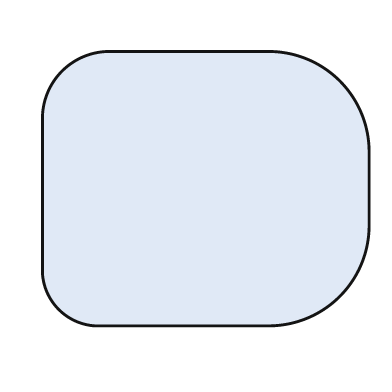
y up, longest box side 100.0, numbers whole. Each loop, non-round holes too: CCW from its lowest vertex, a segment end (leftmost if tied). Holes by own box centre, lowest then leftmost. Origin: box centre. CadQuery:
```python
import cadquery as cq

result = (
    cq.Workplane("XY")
    .moveTo(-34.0, -42.0)
    .lineTo(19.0, -42.0)
    .threePointArc((41.0, -33.0), (50.0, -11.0))
    .lineTo(50.0, 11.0)
    .threePointArc((41.0, 33.0), (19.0, 42.0))
    .lineTo(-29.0, 42.0)
    .threePointArc((-44.0, 36.0), (-50.0, 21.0))
    .lineTo(-50.0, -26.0)
    .threePointArc((-45.0, -37.0), (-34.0, -42.0))
    .close()
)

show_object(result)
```